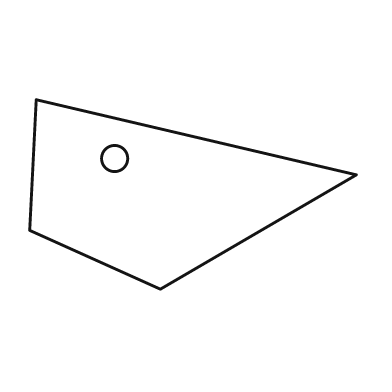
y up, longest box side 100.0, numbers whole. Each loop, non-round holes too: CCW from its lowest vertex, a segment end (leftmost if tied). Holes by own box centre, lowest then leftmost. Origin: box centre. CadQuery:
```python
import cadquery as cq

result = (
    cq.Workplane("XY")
    .moveTo(-10.0, -29.0)
    .lineTo(50.0, 6.0)
    .lineTo(-48.0, 29.0)
    .lineTo(-50.0, -11.0)
    .close()
    .moveTo(-24.0, 11.0)
    .circle(4.0)
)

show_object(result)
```